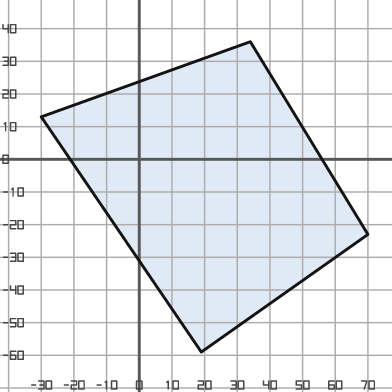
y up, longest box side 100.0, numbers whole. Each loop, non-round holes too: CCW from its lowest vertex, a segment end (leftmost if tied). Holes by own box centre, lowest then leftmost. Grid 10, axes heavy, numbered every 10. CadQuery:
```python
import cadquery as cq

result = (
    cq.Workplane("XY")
    .moveTo(19.0, -59.0)
    .lineTo(70.0, -23.0)
    .lineTo(34.0, 36.0)
    .lineTo(-30.0, 13.0)
    .close()
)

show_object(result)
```